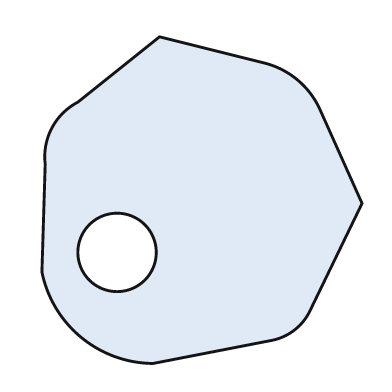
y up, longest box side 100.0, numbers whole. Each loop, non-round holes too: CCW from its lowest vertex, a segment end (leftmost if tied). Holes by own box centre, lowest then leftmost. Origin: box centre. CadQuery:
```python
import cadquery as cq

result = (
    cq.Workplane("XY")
    .moveTo(-15.0, -50.0)
    .lineTo(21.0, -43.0)
    .threePointArc((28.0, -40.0), (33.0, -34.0))
    .lineTo(49.0, -1.0)
    .lineTo(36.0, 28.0)
    .threePointArc((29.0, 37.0), (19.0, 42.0))
    .lineTo(-13.0, 50.0)
    .lineTo(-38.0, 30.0)
    .threePointArc((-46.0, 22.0), (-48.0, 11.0))
    .lineTo(-49.0, -22.0)
    .threePointArc((-37.0, -42.0), (-15.0, -50.0))
    .close()
    .moveTo(-26.0, -16.0)
    .circle(12.0)
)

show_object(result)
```